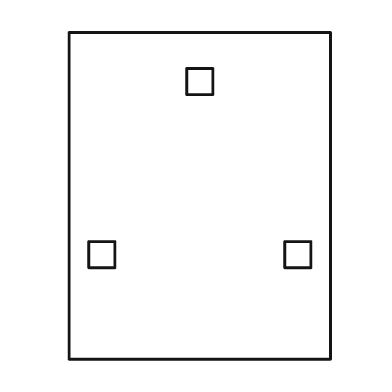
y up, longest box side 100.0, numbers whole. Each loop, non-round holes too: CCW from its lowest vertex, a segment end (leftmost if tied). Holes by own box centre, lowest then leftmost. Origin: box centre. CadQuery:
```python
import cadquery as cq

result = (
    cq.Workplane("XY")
    .moveTo(-40.0, -50.0)
    .lineTo(40.0, -50.0)
    .lineTo(40.0, 50.0)
    .lineTo(-40.0, 50.0)
    .close()
    .moveTo(-34.0, -22.0)
    .lineTo(-26.0, -22.0)
    .lineTo(-26.0, -14.0)
    .lineTo(-34.0, -14.0)
    .close()
    .moveTo(26.0, -22.0)
    .lineTo(34.0, -22.0)
    .lineTo(34.0, -14.0)
    .lineTo(26.0, -14.0)
    .close()
    .moveTo(-4.0, 31.0)
    .lineTo(4.0, 31.0)
    .lineTo(4.0, 39.0)
    .lineTo(-4.0, 39.0)
    .close()
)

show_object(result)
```